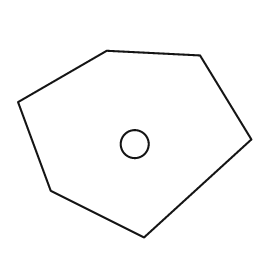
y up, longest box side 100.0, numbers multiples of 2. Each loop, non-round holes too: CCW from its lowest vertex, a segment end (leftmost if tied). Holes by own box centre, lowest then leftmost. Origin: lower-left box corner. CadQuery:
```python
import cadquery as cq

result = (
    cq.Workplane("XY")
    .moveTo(54.0, 0.0)
    .lineTo(100.0, 42.0)
    .lineTo(78.0, 78.0)
    .lineTo(38.0, 80.0)
    .lineTo(0.0, 58.0)
    .lineTo(14.0, 20.0)
    .close()
    .moveTo(50.0, 40.0)
    .circle(6.0)
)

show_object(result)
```